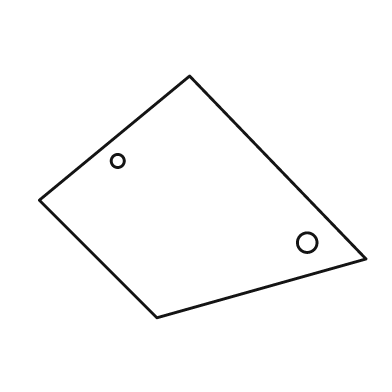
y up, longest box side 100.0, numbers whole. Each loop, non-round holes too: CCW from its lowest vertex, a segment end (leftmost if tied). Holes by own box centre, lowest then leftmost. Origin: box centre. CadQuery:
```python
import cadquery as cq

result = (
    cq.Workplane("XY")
    .moveTo(-14.0, -37.0)
    .lineTo(50.0, -19.0)
    .lineTo(-4.0, 37.0)
    .lineTo(-50.0, -1.0)
    .close()
    .moveTo(32.0, -14.0)
    .circle(3.0)
    .moveTo(-26.0, 11.0)
    .circle(2.0)
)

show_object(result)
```